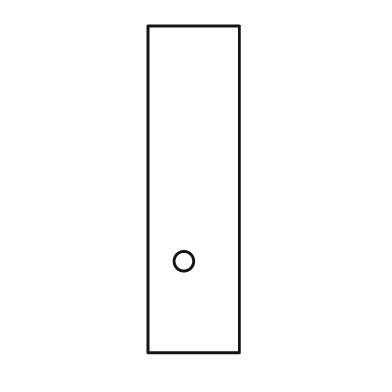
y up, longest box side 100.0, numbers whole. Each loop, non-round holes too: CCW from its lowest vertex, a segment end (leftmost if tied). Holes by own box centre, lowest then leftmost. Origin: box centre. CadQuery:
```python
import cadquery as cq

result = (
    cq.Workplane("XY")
    .moveTo(-14.0, -50.0)
    .lineTo(14.0, -50.0)
    .lineTo(14.0, 50.0)
    .lineTo(-14.0, 50.0)
    .close()
    .moveTo(-3.0, -22.0)
    .circle(3.0)
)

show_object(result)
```